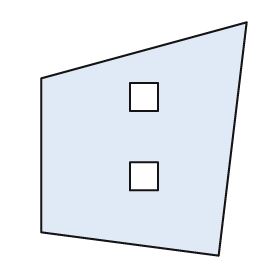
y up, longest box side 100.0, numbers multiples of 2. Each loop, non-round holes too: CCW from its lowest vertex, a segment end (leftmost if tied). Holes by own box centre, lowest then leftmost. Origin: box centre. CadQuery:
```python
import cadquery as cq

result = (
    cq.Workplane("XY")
    .moveTo(32.0, -50.0)
    .lineTo(44.0, 50.0)
    .lineTo(-44.0, 26.0)
    .lineTo(-44.0, -40.0)
    .close()
    .moveTo(-6.0, -22.0)
    .lineTo(6.0, -22.0)
    .lineTo(6.0, -10.0)
    .lineTo(-6.0, -10.0)
    .close()
    .moveTo(-6.0, 12.0)
    .lineTo(6.0, 12.0)
    .lineTo(6.0, 24.0)
    .lineTo(-6.0, 24.0)
    .close()
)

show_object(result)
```